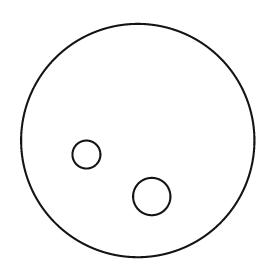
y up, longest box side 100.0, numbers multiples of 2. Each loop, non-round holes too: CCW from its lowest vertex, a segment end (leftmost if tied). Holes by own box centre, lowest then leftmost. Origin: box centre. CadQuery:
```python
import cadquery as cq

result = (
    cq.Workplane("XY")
    .moveTo(0.0, 0.0)
    .circle(50.0)
    .moveTo(6.0, -24.0)
    .circle(8.0)
    .moveTo(-22.0, -6.0)
    .circle(6.0)
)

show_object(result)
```